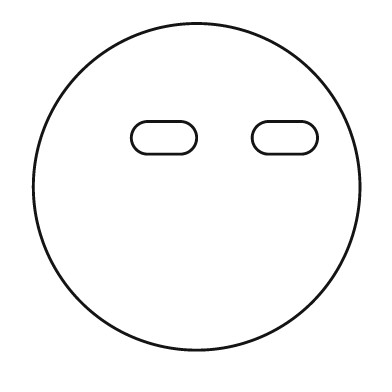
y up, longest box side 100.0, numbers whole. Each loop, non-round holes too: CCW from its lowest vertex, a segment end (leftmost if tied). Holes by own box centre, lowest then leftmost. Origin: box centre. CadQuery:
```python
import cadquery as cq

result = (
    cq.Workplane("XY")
    .moveTo(0.0, 0.0)
    .circle(50.0)
    .moveTo(-15.0, 10.0)
    .lineTo(-5.0, 10.0)
    .threePointArc((0.0, 15.0), (-5.0, 20.0))
    .lineTo(-15.0, 20.0)
    .threePointArc((-20.0, 15.0), (-15.0, 10.0))
    .close()
    .moveTo(22.0, 10.0)
    .lineTo(32.0, 10.0)
    .threePointArc((37.0, 15.0), (32.0, 20.0))
    .lineTo(22.0, 20.0)
    .threePointArc((17.0, 15.0), (22.0, 10.0))
    .close()
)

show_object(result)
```